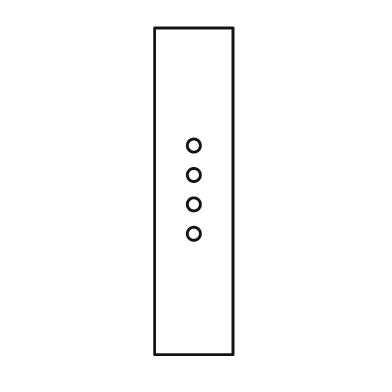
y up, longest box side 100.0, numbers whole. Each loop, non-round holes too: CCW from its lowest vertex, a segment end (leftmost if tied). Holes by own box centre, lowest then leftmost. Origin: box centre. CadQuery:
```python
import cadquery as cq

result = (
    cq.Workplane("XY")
    .moveTo(-12.0, -50.0)
    .lineTo(12.0, -50.0)
    .lineTo(12.0, 50.0)
    .lineTo(-12.0, 50.0)
    .close()
    .moveTo(0.0, -13.0)
    .circle(2.0)
    .moveTo(0.0, -4.0)
    .circle(2.0)
    .moveTo(0.0, 5.0)
    .circle(2.0)
    .moveTo(0.0, 14.0)
    .circle(2.0)
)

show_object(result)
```